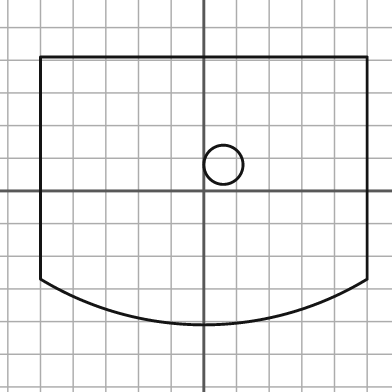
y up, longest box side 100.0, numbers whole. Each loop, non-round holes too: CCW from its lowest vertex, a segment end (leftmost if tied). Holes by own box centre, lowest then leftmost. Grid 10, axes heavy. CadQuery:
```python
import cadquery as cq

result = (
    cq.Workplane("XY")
    .moveTo(-50.0, -27.0)
    .threePointArc((0.0, -41.0), (50.0, -27.0))
    .lineTo(50.0, 41.0)
    .lineTo(-50.0, 41.0)
    .close()
    .moveTo(6.0, 8.0)
    .circle(6.0)
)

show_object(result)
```